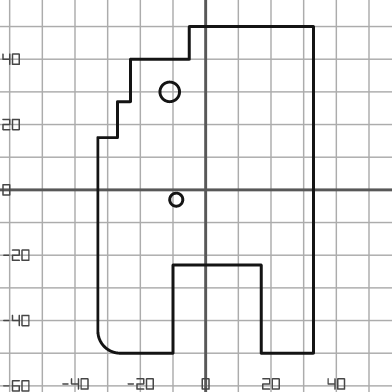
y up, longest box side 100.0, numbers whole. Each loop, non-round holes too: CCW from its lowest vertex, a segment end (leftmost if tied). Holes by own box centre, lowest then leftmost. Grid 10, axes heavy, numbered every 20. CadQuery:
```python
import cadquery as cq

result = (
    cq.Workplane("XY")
    .moveTo(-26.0, -50.0)
    .lineTo(-10.0, -50.0)
    .lineTo(-10.0, -23.0)
    .lineTo(17.0, -23.0)
    .lineTo(17.0, -50.0)
    .lineTo(33.0, -50.0)
    .lineTo(33.0, 50.0)
    .lineTo(-5.0, 50.0)
    .lineTo(-5.0, 40.0)
    .lineTo(-23.0, 40.0)
    .lineTo(-23.0, 27.0)
    .lineTo(-27.0, 27.0)
    .lineTo(-27.0, 16.0)
    .lineTo(-33.0, 16.0)
    .lineTo(-33.0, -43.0)
    .threePointArc((-31.0, -48.0), (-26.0, -50.0))
    .close()
    .moveTo(-9.0, -3.0)
    .circle(2.0)
    .moveTo(-11.0, 30.0)
    .circle(3.0)
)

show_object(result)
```